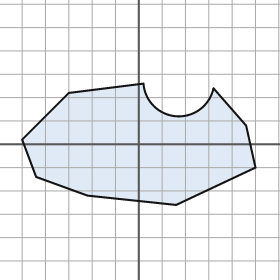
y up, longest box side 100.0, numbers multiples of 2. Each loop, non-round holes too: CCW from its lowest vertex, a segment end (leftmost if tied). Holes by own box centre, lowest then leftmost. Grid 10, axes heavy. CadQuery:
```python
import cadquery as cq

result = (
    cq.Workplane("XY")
    .moveTo(16.0, -26.0)
    .lineTo(50.0, -10.0)
    .lineTo(46.0, 8.0)
    .lineTo(32.0, 24.0)
    .threePointArc((16.0, 12.0), (2.0, 26.0))
    .lineTo(-30.0, 22.0)
    .lineTo(-50.0, 2.0)
    .lineTo(-44.0, -14.0)
    .lineTo(-22.0, -22.0)
    .close()
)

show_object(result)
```